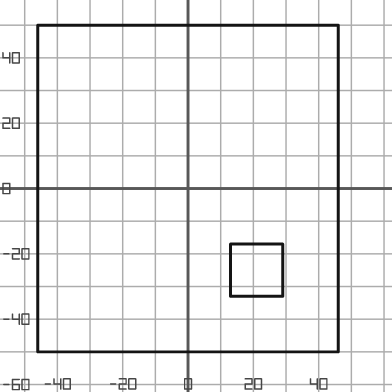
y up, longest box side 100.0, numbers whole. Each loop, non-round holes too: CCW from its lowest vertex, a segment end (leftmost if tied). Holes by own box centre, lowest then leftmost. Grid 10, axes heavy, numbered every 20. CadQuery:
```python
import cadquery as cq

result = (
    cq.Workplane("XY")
    .moveTo(-46.0, -50.0)
    .lineTo(46.0, -50.0)
    .lineTo(46.0, 50.0)
    .lineTo(-46.0, 50.0)
    .close()
    .moveTo(13.0, -33.0)
    .lineTo(29.0, -33.0)
    .lineTo(29.0, -17.0)
    .lineTo(13.0, -17.0)
    .close()
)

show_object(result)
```